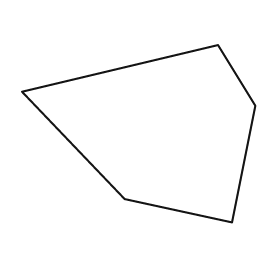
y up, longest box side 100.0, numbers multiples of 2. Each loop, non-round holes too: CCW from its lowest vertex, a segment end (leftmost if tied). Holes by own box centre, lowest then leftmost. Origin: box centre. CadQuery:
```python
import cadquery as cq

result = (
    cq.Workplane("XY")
    .moveTo(40.0, -38.0)
    .lineTo(50.0, 12.0)
    .lineTo(34.0, 38.0)
    .lineTo(-50.0, 18.0)
    .lineTo(-6.0, -28.0)
    .close()
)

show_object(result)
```